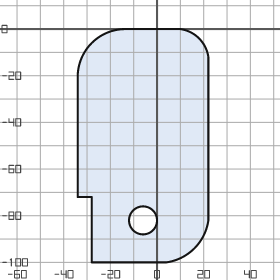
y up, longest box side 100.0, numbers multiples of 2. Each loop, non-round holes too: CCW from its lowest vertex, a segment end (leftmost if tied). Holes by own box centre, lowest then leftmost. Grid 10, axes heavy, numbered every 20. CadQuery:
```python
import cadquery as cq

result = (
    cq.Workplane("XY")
    .moveTo(-28.0, -100.0)
    .lineTo(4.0, -100.0)
    .threePointArc((16.0, -94.0), (22.0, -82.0))
    .lineTo(22.0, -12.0)
    .threePointArc((18.0, -4.0), (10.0, 0.0))
    .lineTo(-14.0, 0.0)
    .threePointArc((-28.0, -6.0), (-34.0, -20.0))
    .lineTo(-34.0, -72.0)
    .lineTo(-28.0, -72.0)
    .close()
    .moveTo(-6.0, -82.0)
    .circle(6.0)
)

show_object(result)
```